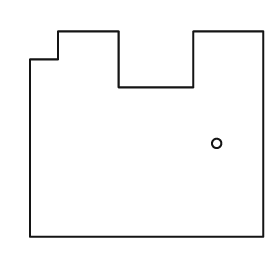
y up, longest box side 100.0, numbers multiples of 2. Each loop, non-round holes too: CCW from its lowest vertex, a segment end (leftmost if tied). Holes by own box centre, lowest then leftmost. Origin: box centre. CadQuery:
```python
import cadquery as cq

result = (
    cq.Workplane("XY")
    .moveTo(-50.0, -44.0)
    .lineTo(50.0, -44.0)
    .lineTo(50.0, 44.0)
    .lineTo(20.0, 44.0)
    .lineTo(20.0, 20.0)
    .lineTo(-12.0, 20.0)
    .lineTo(-12.0, 44.0)
    .lineTo(-38.0, 44.0)
    .lineTo(-38.0, 32.0)
    .lineTo(-50.0, 32.0)
    .close()
    .moveTo(30.0, -4.0)
    .circle(2.0)
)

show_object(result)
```